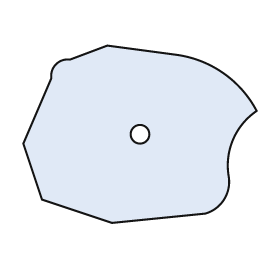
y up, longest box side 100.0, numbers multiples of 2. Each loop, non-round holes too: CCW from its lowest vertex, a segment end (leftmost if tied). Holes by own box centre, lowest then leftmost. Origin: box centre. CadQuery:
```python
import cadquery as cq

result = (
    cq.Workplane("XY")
    .moveTo(-12.0, -38.0)
    .lineTo(28.0, -34.0)
    .threePointArc((36.0, -28.0), (38.0, -18.0))
    .threePointArc((40.0, -2.0), (50.0, 10.0))
    .threePointArc((36.0, 26.0), (16.0, 34.0))
    .lineTo(-14.0, 38.0)
    .lineTo(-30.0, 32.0)
    .threePointArc((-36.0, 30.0), (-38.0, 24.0))
    .lineTo(-50.0, -4.0)
    .lineTo(-42.0, -28.0)
    .close()
    .moveTo(0.0, 0.0)
    .circle(4.0)
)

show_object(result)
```